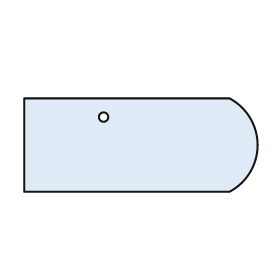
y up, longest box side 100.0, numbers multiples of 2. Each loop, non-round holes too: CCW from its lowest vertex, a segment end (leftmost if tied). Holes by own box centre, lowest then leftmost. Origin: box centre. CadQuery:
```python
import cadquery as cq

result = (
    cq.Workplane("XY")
    .moveTo(-50.0, -20.0)
    .lineTo(38.0, -20.0)
    .threePointArc((50.0, 0.0), (38.0, 20.0))
    .lineTo(-50.0, 20.0)
    .close()
    .moveTo(-16.0, 12.0)
    .circle(2.0)
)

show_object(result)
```